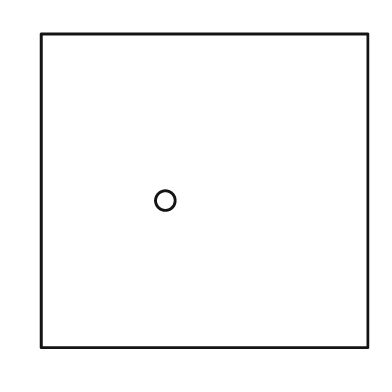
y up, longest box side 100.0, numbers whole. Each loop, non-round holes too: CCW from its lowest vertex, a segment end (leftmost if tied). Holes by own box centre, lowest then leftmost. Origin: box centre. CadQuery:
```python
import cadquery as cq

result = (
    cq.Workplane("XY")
    .moveTo(-50.0, -48.0)
    .lineTo(50.0, -48.0)
    .lineTo(50.0, 48.0)
    .lineTo(-50.0, 48.0)
    .close()
    .moveTo(-12.0, -3.0)
    .circle(3.0)
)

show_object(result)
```